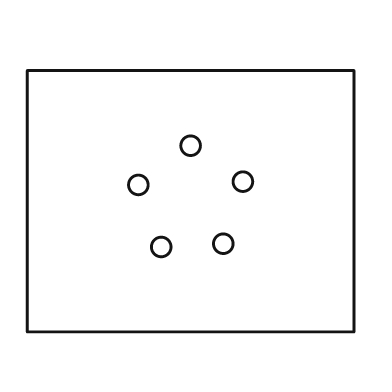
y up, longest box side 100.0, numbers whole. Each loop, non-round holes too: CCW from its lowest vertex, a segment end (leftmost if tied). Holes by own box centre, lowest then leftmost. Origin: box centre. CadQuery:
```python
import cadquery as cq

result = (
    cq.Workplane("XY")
    .moveTo(-50.0, -40.0)
    .lineTo(50.0, -40.0)
    .lineTo(50.0, 40.0)
    .lineTo(-50.0, 40.0)
    .close()
    .moveTo(-9.0, -14.0)
    .circle(3.0)
    .moveTo(10.0, -13.0)
    .circle(3.0)
    .moveTo(-16.0, 5.0)
    .circle(3.0)
    .moveTo(16.0, 6.0)
    .circle(3.0)
    .moveTo(0.0, 17.0)
    .circle(3.0)
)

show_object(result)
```